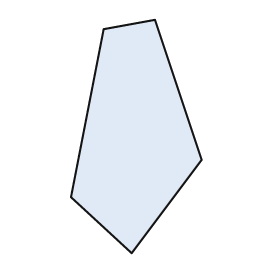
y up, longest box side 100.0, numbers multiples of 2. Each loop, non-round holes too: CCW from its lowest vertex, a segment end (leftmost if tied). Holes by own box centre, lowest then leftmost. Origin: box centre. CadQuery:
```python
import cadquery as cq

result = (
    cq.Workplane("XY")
    .moveTo(-2.0, -50.0)
    .lineTo(28.0, -10.0)
    .lineTo(8.0, 50.0)
    .lineTo(-14.0, 46.0)
    .lineTo(-28.0, -26.0)
    .close()
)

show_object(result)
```